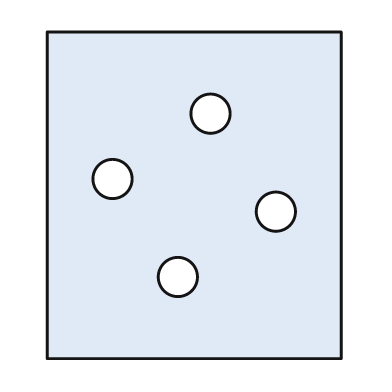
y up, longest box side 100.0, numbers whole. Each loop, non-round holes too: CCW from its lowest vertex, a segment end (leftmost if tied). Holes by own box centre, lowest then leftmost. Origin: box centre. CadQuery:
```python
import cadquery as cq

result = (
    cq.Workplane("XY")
    .moveTo(-45.0, -50.0)
    .lineTo(45.0, -50.0)
    .lineTo(45.0, 50.0)
    .lineTo(-45.0, 50.0)
    .close()
    .moveTo(-5.0, -25.0)
    .circle(6.0)
    .moveTo(25.0, -5.0)
    .circle(6.0)
    .moveTo(-25.0, 5.0)
    .circle(6.0)
    .moveTo(5.0, 25.0)
    .circle(6.0)
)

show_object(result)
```